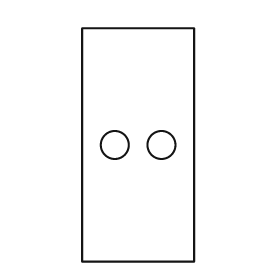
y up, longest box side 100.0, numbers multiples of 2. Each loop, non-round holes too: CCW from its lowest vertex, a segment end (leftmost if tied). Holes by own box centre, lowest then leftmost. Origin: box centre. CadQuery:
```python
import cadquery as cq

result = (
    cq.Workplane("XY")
    .moveTo(-24.0, -50.0)
    .lineTo(24.0, -50.0)
    .lineTo(24.0, 50.0)
    .lineTo(-24.0, 50.0)
    .close()
    .moveTo(-10.0, 0.0)
    .circle(6.0)
    .moveTo(10.0, 0.0)
    .circle(6.0)
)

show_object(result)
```